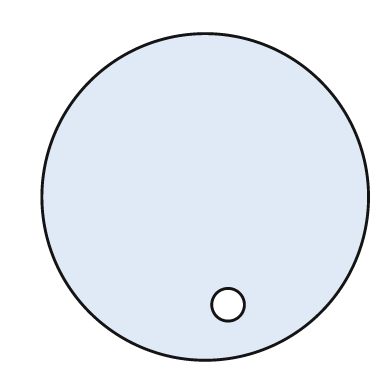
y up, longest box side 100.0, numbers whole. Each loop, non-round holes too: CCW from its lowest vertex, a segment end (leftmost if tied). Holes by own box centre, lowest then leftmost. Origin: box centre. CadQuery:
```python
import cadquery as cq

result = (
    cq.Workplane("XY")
    .moveTo(0.0, 0.0)
    .circle(50.0)
    .moveTo(7.0, -33.0)
    .circle(5.0)
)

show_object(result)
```